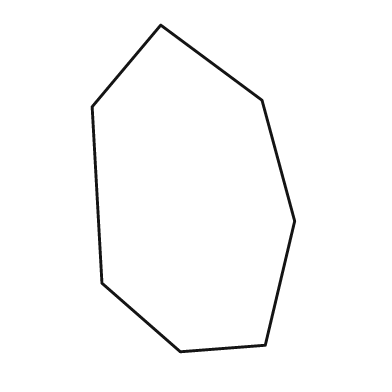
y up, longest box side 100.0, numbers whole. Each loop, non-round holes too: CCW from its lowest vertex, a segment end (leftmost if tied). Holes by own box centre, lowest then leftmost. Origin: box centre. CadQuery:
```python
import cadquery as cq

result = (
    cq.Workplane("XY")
    .moveTo(-4.0, -50.0)
    .lineTo(22.0, -48.0)
    .lineTo(31.0, -10.0)
    .lineTo(21.0, 27.0)
    .lineTo(-10.0, 50.0)
    .lineTo(-31.0, 25.0)
    .lineTo(-28.0, -29.0)
    .close()
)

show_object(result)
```